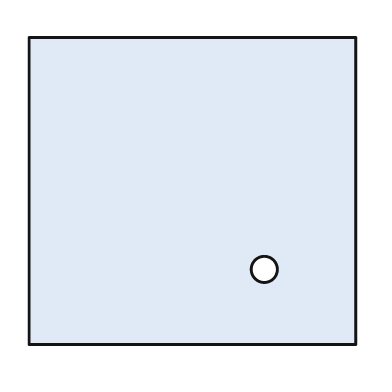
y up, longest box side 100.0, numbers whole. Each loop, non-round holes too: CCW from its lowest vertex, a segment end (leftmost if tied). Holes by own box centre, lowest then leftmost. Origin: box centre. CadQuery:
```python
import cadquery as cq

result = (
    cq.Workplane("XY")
    .moveTo(-50.0, -47.0)
    .lineTo(50.0, -47.0)
    .lineTo(50.0, 47.0)
    .lineTo(-50.0, 47.0)
    .close()
    .moveTo(22.0, -24.0)
    .circle(4.0)
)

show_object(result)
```